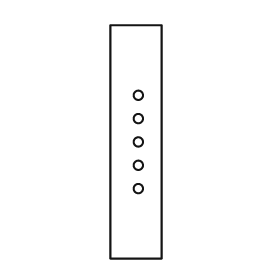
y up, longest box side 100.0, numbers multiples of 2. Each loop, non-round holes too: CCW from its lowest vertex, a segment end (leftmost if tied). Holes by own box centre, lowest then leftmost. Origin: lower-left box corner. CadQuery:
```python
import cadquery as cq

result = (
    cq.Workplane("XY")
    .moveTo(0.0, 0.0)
    .lineTo(22.0, 0.0)
    .lineTo(22.0, 100.0)
    .lineTo(0.0, 100.0)
    .close()
    .moveTo(12.0, 30.0)
    .circle(2.0)
    .moveTo(12.0, 40.0)
    .circle(2.0)
    .moveTo(12.0, 50.0)
    .circle(2.0)
    .moveTo(12.0, 60.0)
    .circle(2.0)
    .moveTo(12.0, 70.0)
    .circle(2.0)
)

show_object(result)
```